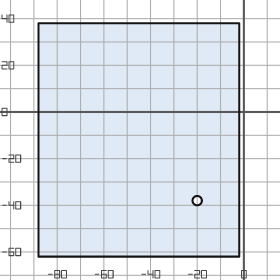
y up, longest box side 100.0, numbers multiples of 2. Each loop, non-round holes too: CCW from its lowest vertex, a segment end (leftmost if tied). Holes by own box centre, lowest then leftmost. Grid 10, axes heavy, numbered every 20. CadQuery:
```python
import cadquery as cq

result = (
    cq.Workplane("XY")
    .moveTo(-88.0, -62.0)
    .lineTo(-2.0, -62.0)
    .lineTo(-2.0, 38.0)
    .lineTo(-88.0, 38.0)
    .close()
    .moveTo(-20.0, -38.0)
    .circle(2.0)
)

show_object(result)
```